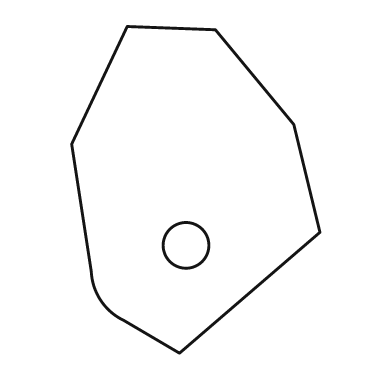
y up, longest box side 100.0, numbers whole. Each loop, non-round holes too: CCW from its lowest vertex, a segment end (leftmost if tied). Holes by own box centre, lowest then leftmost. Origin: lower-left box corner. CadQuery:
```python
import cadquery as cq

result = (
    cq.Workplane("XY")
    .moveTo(33.0, 0.0)
    .lineTo(76.0, 37.0)
    .lineTo(68.0, 70.0)
    .lineTo(44.0, 99.0)
    .lineTo(17.0, 100.0)
    .lineTo(0.0, 64.0)
    .lineTo(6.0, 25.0)
    .threePointArc((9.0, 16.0), (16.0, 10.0))
    .close()
    .moveTo(35.0, 33.0)
    .circle(7.0)
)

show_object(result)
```